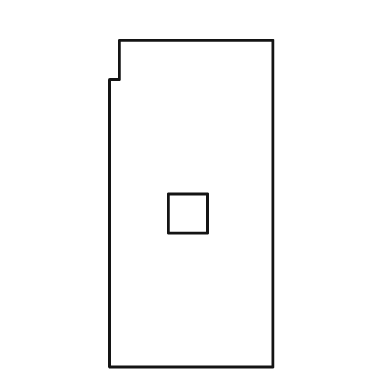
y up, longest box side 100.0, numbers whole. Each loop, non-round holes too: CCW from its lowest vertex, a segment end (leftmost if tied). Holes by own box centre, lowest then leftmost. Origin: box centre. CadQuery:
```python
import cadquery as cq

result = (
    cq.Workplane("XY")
    .moveTo(-25.0, -50.0)
    .lineTo(25.0, -50.0)
    .lineTo(25.0, 50.0)
    .lineTo(-22.0, 50.0)
    .lineTo(-22.0, 38.0)
    .lineTo(-25.0, 38.0)
    .close()
    .moveTo(-7.0, -9.0)
    .lineTo(5.0, -9.0)
    .lineTo(5.0, 3.0)
    .lineTo(-7.0, 3.0)
    .close()
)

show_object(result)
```